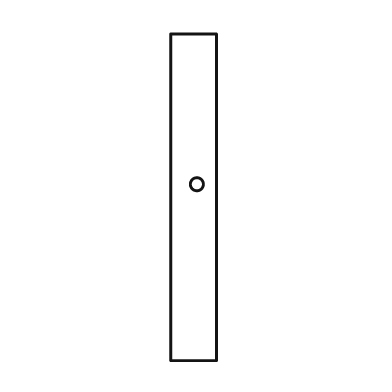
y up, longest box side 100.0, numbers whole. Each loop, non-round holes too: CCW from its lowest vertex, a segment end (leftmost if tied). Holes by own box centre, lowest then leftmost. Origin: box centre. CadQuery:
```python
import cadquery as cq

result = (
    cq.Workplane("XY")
    .moveTo(-7.0, -50.0)
    .lineTo(7.0, -50.0)
    .lineTo(7.0, 50.0)
    .lineTo(-7.0, 50.0)
    .close()
    .moveTo(1.0, 4.0)
    .circle(2.0)
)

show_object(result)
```